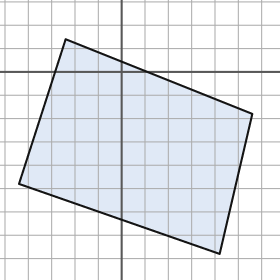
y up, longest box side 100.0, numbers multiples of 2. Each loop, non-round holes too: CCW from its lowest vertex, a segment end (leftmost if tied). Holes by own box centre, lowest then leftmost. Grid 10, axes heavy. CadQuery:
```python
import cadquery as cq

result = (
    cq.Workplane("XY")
    .moveTo(42.0, -78.0)
    .lineTo(56.0, -18.0)
    .lineTo(-24.0, 14.0)
    .lineTo(-44.0, -48.0)
    .close()
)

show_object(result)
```